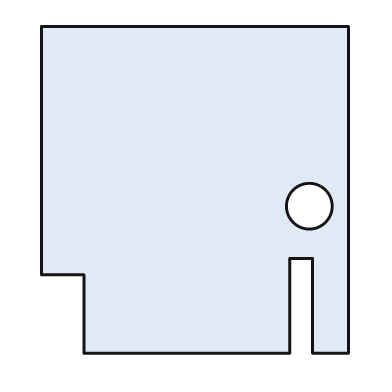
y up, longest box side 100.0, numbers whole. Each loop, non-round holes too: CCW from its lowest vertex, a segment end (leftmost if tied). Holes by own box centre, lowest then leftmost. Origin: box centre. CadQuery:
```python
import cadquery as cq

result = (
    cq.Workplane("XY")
    .moveTo(-34.0, -50.0)
    .lineTo(29.0, -50.0)
    .lineTo(29.0, -21.0)
    .lineTo(36.0, -21.0)
    .lineTo(36.0, -50.0)
    .lineTo(47.0, -50.0)
    .lineTo(47.0, 50.0)
    .lineTo(-47.0, 50.0)
    .lineTo(-47.0, -26.0)
    .lineTo(-34.0, -26.0)
    .close()
    .moveTo(35.0, -5.0)
    .circle(7.0)
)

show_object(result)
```